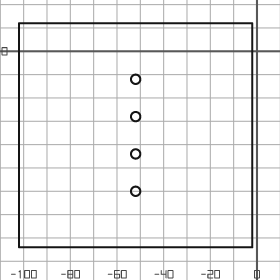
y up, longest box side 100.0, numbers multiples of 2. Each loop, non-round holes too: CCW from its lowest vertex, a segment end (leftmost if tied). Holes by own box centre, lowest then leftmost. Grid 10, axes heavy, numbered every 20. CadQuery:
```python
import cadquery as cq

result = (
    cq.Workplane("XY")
    .moveTo(-102.0, -84.0)
    .lineTo(-2.0, -84.0)
    .lineTo(-2.0, 12.0)
    .lineTo(-102.0, 12.0)
    .close()
    .moveTo(-52.0, -60.0)
    .circle(2.0)
    .moveTo(-52.0, -44.0)
    .circle(2.0)
    .moveTo(-52.0, -28.0)
    .circle(2.0)
    .moveTo(-52.0, -12.0)
    .circle(2.0)
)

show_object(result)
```